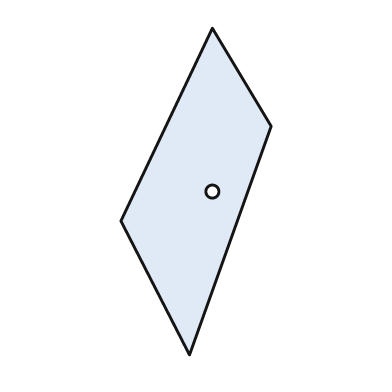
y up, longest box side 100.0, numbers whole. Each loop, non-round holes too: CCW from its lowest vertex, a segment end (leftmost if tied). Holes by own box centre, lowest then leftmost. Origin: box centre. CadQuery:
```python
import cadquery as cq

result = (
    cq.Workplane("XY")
    .moveTo(-2.0, -50.0)
    .lineTo(23.0, 20.0)
    .lineTo(5.0, 50.0)
    .lineTo(-23.0, -9.0)
    .close()
    .moveTo(5.0, 0.0)
    .circle(2.0)
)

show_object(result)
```